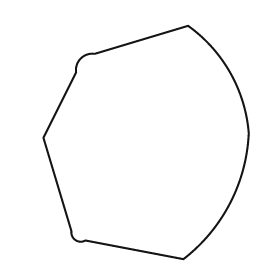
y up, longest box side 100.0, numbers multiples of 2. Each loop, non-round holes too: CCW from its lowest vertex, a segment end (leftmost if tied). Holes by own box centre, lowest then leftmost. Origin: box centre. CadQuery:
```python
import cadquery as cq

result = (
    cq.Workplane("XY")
    .moveTo(16.0, -50.0)
    .threePointArc((36.0, -26.0), (44.0, 4.0))
    .threePointArc((36.0, 30.0), (18.0, 50.0))
    .lineTo(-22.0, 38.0)
    .threePointArc((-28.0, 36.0), (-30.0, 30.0))
    .lineTo(-44.0, 2.0)
    .lineTo(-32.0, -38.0)
    .threePointArc((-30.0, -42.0), (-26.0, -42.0))
    .close()
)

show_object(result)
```